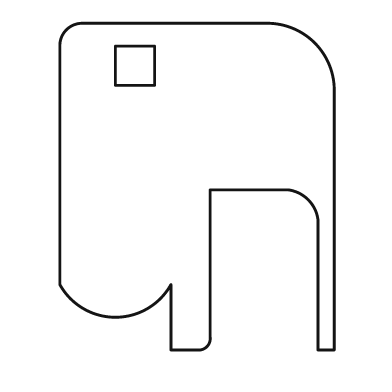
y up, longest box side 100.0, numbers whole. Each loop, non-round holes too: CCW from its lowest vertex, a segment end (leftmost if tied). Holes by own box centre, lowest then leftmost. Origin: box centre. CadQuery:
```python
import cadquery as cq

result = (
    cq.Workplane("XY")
    .moveTo(-8.0, -50.0)
    .lineTo(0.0, -50.0)
    .threePointArc((3.0, -49.0), (4.0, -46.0))
    .lineTo(4.0, -1.0)
    .lineTo(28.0, -1.0)
    .threePointArc((34.0, -4.0), (37.0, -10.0))
    .lineTo(37.0, -50.0)
    .lineTo(42.0, -50.0)
    .lineTo(42.0, 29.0)
    .threePointArc((36.0, 44.0), (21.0, 50.0))
    .lineTo(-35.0, 50.0)
    .threePointArc((-40.0, 48.0), (-42.0, 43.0))
    .lineTo(-42.0, -30.0)
    .threePointArc((-25.0, -40.0), (-8.0, -30.0))
    .close()
    .moveTo(-25.0, 31.0)
    .lineTo(-13.0, 31.0)
    .lineTo(-13.0, 43.0)
    .lineTo(-25.0, 43.0)
    .close()
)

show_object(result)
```